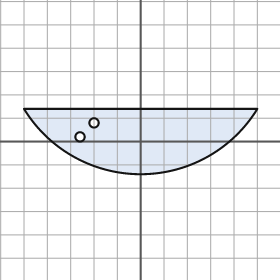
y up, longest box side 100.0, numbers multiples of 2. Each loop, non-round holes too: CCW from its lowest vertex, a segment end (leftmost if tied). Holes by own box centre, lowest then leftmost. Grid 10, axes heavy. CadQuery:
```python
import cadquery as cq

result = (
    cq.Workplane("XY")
    .moveTo(-50.0, 14.0)
    .threePointArc((0.0, -14.0), (50.0, 14.0))
    .close()
    .moveTo(-26.0, 2.0)
    .circle(2.0)
    .moveTo(-20.0, 8.0)
    .circle(2.0)
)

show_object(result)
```